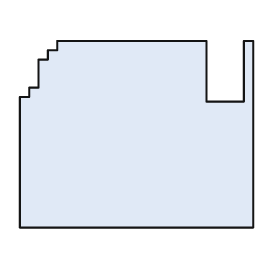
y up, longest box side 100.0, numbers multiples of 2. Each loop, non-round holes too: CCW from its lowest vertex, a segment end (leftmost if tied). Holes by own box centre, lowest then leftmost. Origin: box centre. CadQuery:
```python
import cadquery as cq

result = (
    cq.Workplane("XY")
    .moveTo(-50.0, -40.0)
    .lineTo(50.0, -40.0)
    .lineTo(50.0, 40.0)
    .lineTo(46.0, 40.0)
    .lineTo(46.0, 14.0)
    .lineTo(30.0, 14.0)
    .lineTo(30.0, 40.0)
    .lineTo(-34.0, 40.0)
    .lineTo(-34.0, 36.0)
    .lineTo(-38.0, 36.0)
    .lineTo(-38.0, 32.0)
    .lineTo(-42.0, 32.0)
    .lineTo(-42.0, 20.0)
    .lineTo(-46.0, 20.0)
    .lineTo(-46.0, 16.0)
    .lineTo(-50.0, 16.0)
    .close()
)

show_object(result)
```